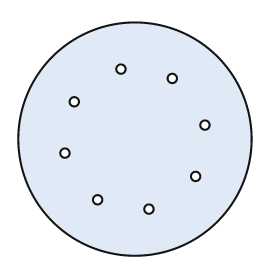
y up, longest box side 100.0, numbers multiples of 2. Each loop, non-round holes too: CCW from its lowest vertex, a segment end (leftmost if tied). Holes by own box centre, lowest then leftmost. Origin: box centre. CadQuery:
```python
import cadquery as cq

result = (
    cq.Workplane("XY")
    .moveTo(0.0, 0.0)
    .circle(50.0)
    .moveTo(6.0, -30.0)
    .circle(2.0)
    .moveTo(-16.0, -26.0)
    .circle(2.0)
    .moveTo(26.0, -16.0)
    .circle(2.0)
    .moveTo(-30.0, -6.0)
    .circle(2.0)
    .moveTo(30.0, 6.0)
    .circle(2.0)
    .moveTo(-26.0, 16.0)
    .circle(2.0)
    .moveTo(16.0, 26.0)
    .circle(2.0)
    .moveTo(-6.0, 30.0)
    .circle(2.0)
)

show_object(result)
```